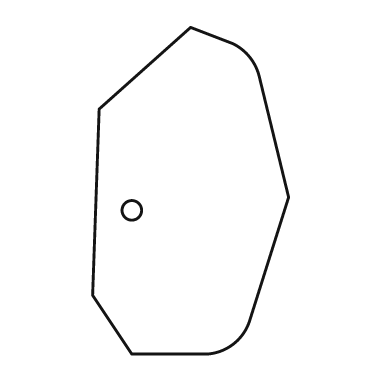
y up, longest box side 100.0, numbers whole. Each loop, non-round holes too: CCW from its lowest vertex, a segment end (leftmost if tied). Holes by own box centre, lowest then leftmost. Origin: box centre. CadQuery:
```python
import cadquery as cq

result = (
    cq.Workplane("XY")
    .moveTo(-18.0, -50.0)
    .lineTo(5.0, -50.0)
    .threePointArc((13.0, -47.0), (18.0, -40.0))
    .lineTo(30.0, -2.0)
    .lineTo(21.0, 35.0)
    .threePointArc((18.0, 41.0), (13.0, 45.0))
    .lineTo(0.0, 50.0)
    .lineTo(-28.0, 25.0)
    .lineTo(-30.0, -32.0)
    .close()
    .moveTo(-18.0, -6.0)
    .circle(3.0)
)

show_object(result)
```